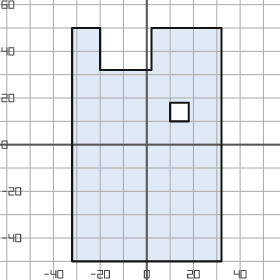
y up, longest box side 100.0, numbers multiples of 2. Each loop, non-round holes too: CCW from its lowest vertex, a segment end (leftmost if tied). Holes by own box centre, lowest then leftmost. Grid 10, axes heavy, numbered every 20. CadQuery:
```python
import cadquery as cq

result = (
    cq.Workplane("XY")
    .moveTo(-32.0, -50.0)
    .lineTo(32.0, -50.0)
    .lineTo(32.0, 50.0)
    .lineTo(2.0, 50.0)
    .lineTo(2.0, 32.0)
    .lineTo(-20.0, 32.0)
    .lineTo(-20.0, 50.0)
    .lineTo(-32.0, 50.0)
    .close()
    .moveTo(10.0, 10.0)
    .lineTo(18.0, 10.0)
    .lineTo(18.0, 18.0)
    .lineTo(10.0, 18.0)
    .close()
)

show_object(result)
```